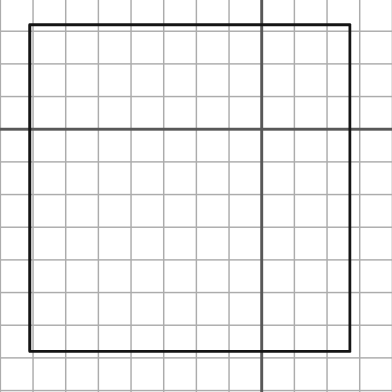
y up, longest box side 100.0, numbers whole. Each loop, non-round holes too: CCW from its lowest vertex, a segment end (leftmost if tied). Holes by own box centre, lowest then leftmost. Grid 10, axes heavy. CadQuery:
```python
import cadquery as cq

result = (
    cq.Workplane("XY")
    .moveTo(-71.0, -68.0)
    .lineTo(27.0, -68.0)
    .lineTo(27.0, 32.0)
    .lineTo(-71.0, 32.0)
    .close()
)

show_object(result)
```